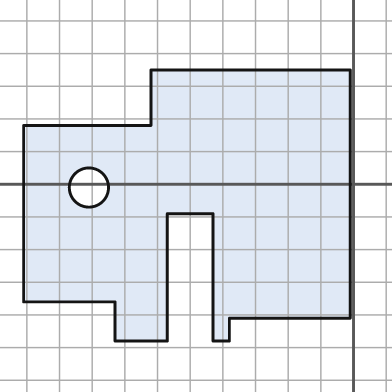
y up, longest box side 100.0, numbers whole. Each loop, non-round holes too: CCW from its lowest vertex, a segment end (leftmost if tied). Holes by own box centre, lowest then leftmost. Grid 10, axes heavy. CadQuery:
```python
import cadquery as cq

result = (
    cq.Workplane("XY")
    .moveTo(-73.0, -48.0)
    .lineTo(-57.0, -48.0)
    .lineTo(-57.0, -9.0)
    .lineTo(-43.0, -9.0)
    .lineTo(-43.0, -48.0)
    .lineTo(-38.0, -48.0)
    .lineTo(-38.0, -41.0)
    .lineTo(-1.0, -41.0)
    .lineTo(-1.0, 35.0)
    .lineTo(-62.0, 35.0)
    .lineTo(-62.0, 18.0)
    .lineTo(-101.0, 18.0)
    .lineTo(-101.0, -36.0)
    .lineTo(-73.0, -36.0)
    .close()
    .moveTo(-81.0, -1.0)
    .circle(6.0)
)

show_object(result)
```